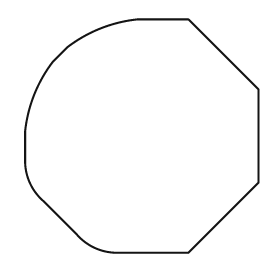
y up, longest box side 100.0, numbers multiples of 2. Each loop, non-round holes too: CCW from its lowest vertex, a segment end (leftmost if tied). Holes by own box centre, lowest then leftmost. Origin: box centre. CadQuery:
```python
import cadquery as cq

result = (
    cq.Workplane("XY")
    .moveTo(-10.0, -50.0)
    .lineTo(20.0, -50.0)
    .lineTo(50.0, -20.0)
    .lineTo(50.0, 20.0)
    .lineTo(20.0, 50.0)
    .lineTo(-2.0, 50.0)
    .threePointArc((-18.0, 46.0), (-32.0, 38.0))
    .lineTo(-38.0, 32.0)
    .threePointArc((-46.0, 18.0), (-50.0, 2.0))
    .lineTo(-50.0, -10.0)
    .threePointArc((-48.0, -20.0), (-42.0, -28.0))
    .lineTo(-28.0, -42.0)
    .threePointArc((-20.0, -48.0), (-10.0, -50.0))
    .close()
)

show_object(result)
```